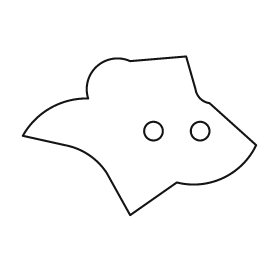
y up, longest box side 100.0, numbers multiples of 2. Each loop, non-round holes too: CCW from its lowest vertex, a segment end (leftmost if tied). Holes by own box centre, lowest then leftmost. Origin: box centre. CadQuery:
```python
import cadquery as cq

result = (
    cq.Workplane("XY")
    .moveTo(-4.0, -34.0)
    .lineTo(16.0, -20.0)
    .threePointArc((36.0, -18.0), (50.0, -4.0))
    .lineTo(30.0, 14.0)
    .threePointArc((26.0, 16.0), (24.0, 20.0))
    .lineTo(20.0, 34.0)
    .lineTo(-4.0, 32.0)
    .threePointArc((-18.0, 30.0), (-22.0, 16.0))
    .threePointArc((-38.0, 12.0), (-50.0, 0.0))
    .lineTo(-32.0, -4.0)
    .threePointArc((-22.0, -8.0), (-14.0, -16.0))
    .close()
    .moveTo(6.0, 2.0)
    .circle(4.0)
    .moveTo(26.0, 2.0)
    .circle(4.0)
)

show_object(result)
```